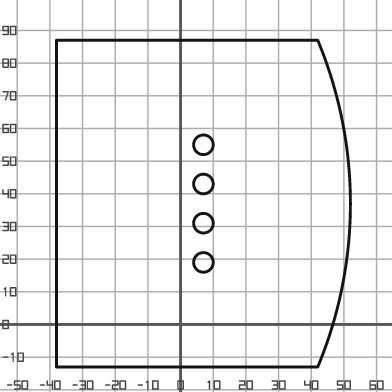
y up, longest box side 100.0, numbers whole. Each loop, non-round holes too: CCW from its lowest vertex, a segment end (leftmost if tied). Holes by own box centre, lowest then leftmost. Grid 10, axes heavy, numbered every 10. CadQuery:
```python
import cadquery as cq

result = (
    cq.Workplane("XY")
    .moveTo(-38.0, -13.0)
    .lineTo(42.0, -13.0)
    .threePointArc((52.0, 37.0), (42.0, 87.0))
    .lineTo(-38.0, 87.0)
    .close()
    .moveTo(7.0, 19.0)
    .circle(3.0)
    .moveTo(7.0, 31.0)
    .circle(3.0)
    .moveTo(7.0, 43.0)
    .circle(3.0)
    .moveTo(7.0, 55.0)
    .circle(3.0)
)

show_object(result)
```